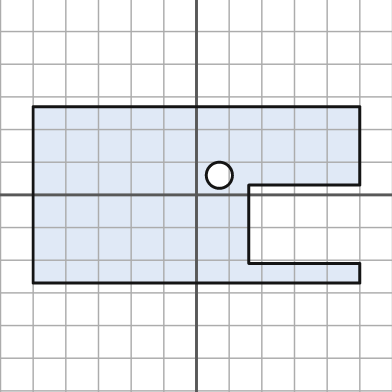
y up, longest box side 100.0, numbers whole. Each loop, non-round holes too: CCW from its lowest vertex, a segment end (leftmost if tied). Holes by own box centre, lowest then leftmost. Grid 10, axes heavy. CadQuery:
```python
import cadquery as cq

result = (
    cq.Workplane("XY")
    .moveTo(-50.0, -27.0)
    .lineTo(50.0, -27.0)
    .lineTo(50.0, -21.0)
    .lineTo(16.0, -21.0)
    .lineTo(16.0, 3.0)
    .lineTo(50.0, 3.0)
    .lineTo(50.0, 27.0)
    .lineTo(-50.0, 27.0)
    .close()
    .moveTo(7.0, 6.0)
    .circle(4.0)
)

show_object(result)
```